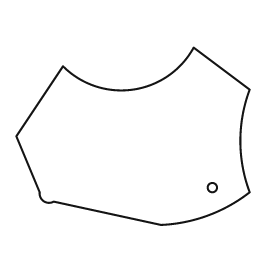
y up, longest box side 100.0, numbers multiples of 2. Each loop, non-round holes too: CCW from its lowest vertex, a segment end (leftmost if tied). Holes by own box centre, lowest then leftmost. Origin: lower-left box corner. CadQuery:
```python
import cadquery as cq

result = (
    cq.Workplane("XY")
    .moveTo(62.0, 0.0)
    .threePointArc((82.0, 4.0), (100.0, 14.0))
    .threePointArc((96.0, 36.0), (100.0, 58.0))
    .lineTo(76.0, 76.0)
    .threePointArc((50.0, 58.0), (20.0, 68.0))
    .lineTo(0.0, 38.0)
    .lineTo(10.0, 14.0)
    .threePointArc((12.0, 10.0), (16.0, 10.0))
    .close()
    .moveTo(84.0, 16.0)
    .circle(2.0)
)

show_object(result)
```